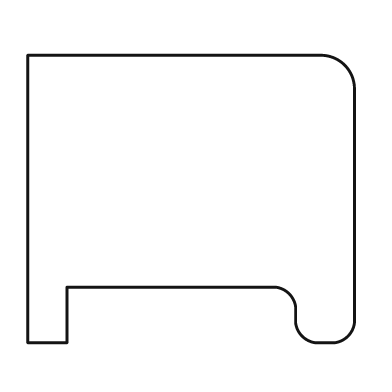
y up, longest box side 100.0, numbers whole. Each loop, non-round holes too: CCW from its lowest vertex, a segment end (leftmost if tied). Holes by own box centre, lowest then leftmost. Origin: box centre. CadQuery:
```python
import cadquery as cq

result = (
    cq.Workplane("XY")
    .moveTo(-50.0, -44.0)
    .lineTo(-38.0, -44.0)
    .lineTo(-38.0, -27.0)
    .lineTo(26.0, -27.0)
    .threePointArc((30.0, -29.0), (32.0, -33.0))
    .lineTo(32.0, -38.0)
    .threePointArc((34.0, -42.0), (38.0, -44.0))
    .lineTo(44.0, -44.0)
    .threePointArc((48.0, -42.0), (50.0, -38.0))
    .lineTo(50.0, 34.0)
    .threePointArc((47.0, 41.0), (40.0, 44.0))
    .lineTo(-50.0, 44.0)
    .close()
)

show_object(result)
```